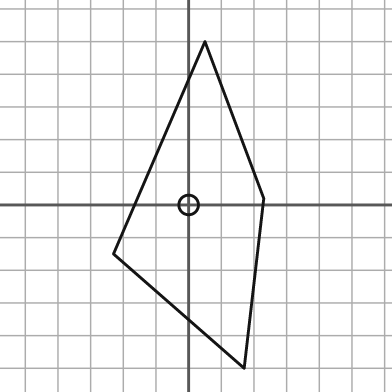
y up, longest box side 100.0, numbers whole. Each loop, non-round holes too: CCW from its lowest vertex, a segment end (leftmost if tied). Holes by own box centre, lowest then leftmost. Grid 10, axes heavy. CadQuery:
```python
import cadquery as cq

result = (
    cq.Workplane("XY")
    .moveTo(17.0, -50.0)
    .lineTo(23.0, 2.0)
    .lineTo(5.0, 50.0)
    .lineTo(-23.0, -15.0)
    .close()
    .moveTo(0.0, 0.0)
    .circle(3.0)
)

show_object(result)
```